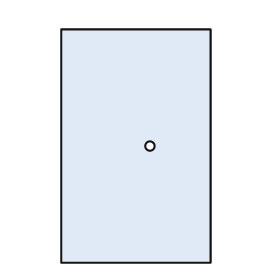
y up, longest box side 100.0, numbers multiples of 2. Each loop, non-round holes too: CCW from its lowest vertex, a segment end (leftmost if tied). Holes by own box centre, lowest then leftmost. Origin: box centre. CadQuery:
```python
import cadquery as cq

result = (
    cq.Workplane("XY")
    .moveTo(-32.0, -50.0)
    .lineTo(32.0, -50.0)
    .lineTo(32.0, 50.0)
    .lineTo(-32.0, 50.0)
    .close()
    .moveTo(6.0, 0.0)
    .circle(2.0)
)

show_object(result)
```